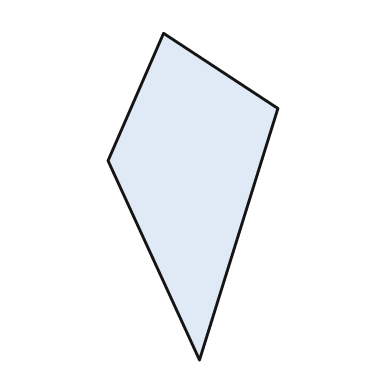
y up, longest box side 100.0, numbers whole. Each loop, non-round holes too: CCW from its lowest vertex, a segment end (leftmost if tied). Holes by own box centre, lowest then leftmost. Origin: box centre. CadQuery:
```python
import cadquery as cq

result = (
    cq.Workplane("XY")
    .moveTo(2.0, -50.0)
    .lineTo(26.0, 27.0)
    .lineTo(-9.0, 50.0)
    .lineTo(-26.0, 11.0)
    .close()
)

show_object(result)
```